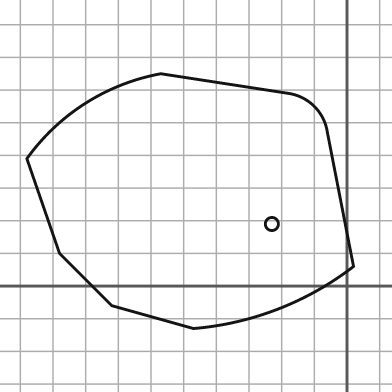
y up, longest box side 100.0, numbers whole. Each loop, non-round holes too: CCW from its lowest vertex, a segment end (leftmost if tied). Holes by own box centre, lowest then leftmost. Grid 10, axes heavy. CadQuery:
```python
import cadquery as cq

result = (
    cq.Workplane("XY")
    .moveTo(-47.0, -13.0)
    .threePointArc((-21.0, -7.0), (2.0, 6.0))
    .lineTo(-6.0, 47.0)
    .threePointArc((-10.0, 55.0), (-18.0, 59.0))
    .lineTo(-57.0, 65.0)
    .threePointArc((-80.0, 56.0), (-98.0, 39.0))
    .lineTo(-88.0, 10.0)
    .lineTo(-72.0, -6.0)
    .close()
    .moveTo(-23.0, 19.0)
    .circle(2.0)
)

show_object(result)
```